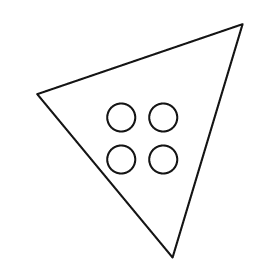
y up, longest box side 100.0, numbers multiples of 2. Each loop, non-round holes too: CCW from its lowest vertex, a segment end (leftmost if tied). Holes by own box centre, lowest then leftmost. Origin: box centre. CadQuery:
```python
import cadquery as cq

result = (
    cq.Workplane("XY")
    .moveTo(14.0, -50.0)
    .lineTo(44.0, 50.0)
    .lineTo(-44.0, 20.0)
    .close()
    .moveTo(-8.0, -8.0)
    .circle(6.0)
    .moveTo(10.0, -8.0)
    .circle(6.0)
    .moveTo(-8.0, 10.0)
    .circle(6.0)
    .moveTo(10.0, 10.0)
    .circle(6.0)
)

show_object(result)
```